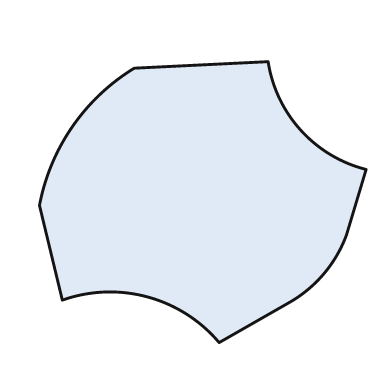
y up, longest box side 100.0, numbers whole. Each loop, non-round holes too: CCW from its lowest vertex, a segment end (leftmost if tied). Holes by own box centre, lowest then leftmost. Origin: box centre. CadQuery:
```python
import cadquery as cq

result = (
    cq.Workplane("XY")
    .moveTo(5.0, -43.0)
    .lineTo(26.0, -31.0)
    .threePointArc((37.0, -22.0), (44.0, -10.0))
    .lineTo(50.0, 10.0)
    .threePointArc((30.0, 22.0), (20.0, 43.0))
    .lineTo(-21.0, 41.0)
    .threePointArc((-40.0, 23.0), (-50.0, -1.0))
    .lineTo(-43.0, -30.0)
    .threePointArc((-17.0, -29.0), (5.0, -43.0))
    .close()
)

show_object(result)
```